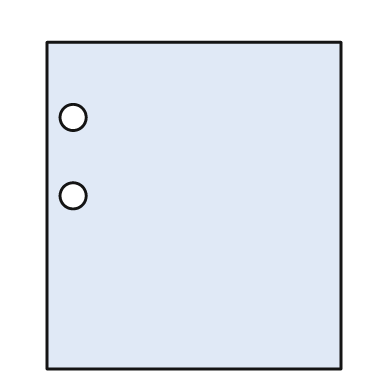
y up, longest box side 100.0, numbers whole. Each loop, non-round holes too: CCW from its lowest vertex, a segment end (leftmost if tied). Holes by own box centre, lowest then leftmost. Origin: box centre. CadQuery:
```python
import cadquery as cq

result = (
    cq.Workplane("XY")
    .moveTo(-45.0, -50.0)
    .lineTo(45.0, -50.0)
    .lineTo(45.0, 50.0)
    .lineTo(-45.0, 50.0)
    .close()
    .moveTo(-37.0, 3.0)
    .circle(4.0)
    .moveTo(-37.0, 27.0)
    .circle(4.0)
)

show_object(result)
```